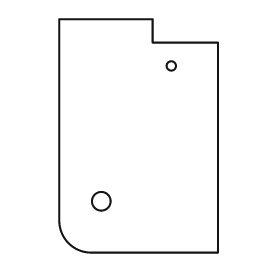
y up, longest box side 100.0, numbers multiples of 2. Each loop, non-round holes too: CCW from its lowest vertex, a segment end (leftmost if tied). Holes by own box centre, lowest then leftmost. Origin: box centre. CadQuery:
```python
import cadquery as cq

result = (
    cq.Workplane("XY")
    .moveTo(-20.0, -50.0)
    .lineTo(34.0, -50.0)
    .lineTo(34.0, 40.0)
    .lineTo(6.0, 40.0)
    .lineTo(6.0, 50.0)
    .lineTo(-34.0, 50.0)
    .lineTo(-34.0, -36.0)
    .threePointArc((-30.0, -46.0), (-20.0, -50.0))
    .close()
    .moveTo(-16.0, -28.0)
    .circle(4.0)
    .moveTo(14.0, 30.0)
    .circle(2.0)
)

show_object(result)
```